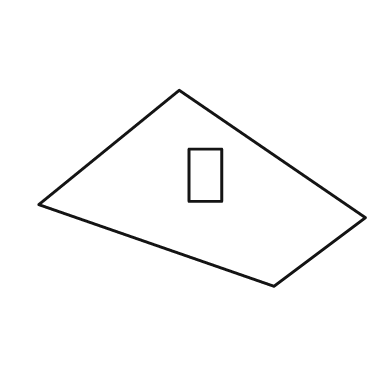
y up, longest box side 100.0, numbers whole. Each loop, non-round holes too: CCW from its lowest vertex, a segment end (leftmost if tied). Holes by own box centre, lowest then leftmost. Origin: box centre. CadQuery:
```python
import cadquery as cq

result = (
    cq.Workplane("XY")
    .moveTo(22.0, -30.0)
    .lineTo(50.0, -9.0)
    .lineTo(-7.0, 30.0)
    .lineTo(-50.0, -5.0)
    .close()
    .moveTo(-4.0, -4.0)
    .lineTo(6.0, -4.0)
    .lineTo(6.0, 12.0)
    .lineTo(-4.0, 12.0)
    .close()
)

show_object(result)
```